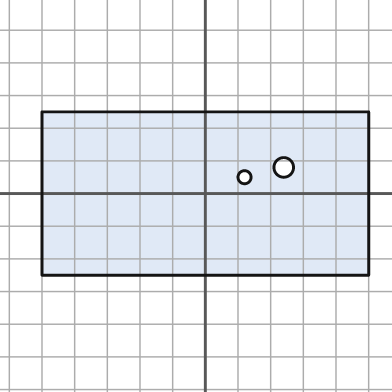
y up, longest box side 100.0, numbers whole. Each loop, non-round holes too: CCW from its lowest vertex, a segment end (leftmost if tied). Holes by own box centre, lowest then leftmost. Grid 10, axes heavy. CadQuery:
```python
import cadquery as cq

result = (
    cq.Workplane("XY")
    .moveTo(-50.0, -25.0)
    .lineTo(50.0, -25.0)
    .lineTo(50.0, 25.0)
    .lineTo(-50.0, 25.0)
    .close()
    .moveTo(12.0, 5.0)
    .circle(2.0)
    .moveTo(24.0, 8.0)
    .circle(3.0)
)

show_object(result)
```